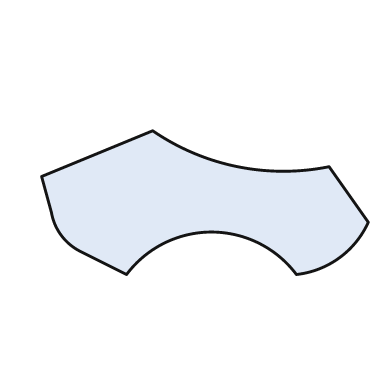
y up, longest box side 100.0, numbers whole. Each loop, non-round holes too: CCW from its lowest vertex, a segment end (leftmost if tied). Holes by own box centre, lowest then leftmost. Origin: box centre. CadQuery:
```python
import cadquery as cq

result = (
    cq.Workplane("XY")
    .moveTo(-24.0, -22.0)
    .threePointArc((2.0, -9.0), (28.0, -22.0))
    .threePointArc((41.0, -17.0), (50.0, -6.0))
    .lineTo(38.0, 11.0)
    .threePointArc((10.0, 11.0), (-16.0, 22.0))
    .lineTo(-50.0, 8.0)
    .lineTo(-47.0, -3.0)
    .threePointArc((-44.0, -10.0), (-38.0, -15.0))
    .close()
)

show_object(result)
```